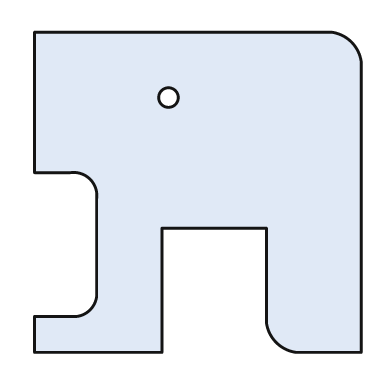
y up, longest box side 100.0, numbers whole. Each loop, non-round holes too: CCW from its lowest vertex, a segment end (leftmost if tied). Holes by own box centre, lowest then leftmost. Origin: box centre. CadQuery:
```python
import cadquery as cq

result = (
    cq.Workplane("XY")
    .moveTo(-50.0, -49.0)
    .lineTo(-11.0, -49.0)
    .lineTo(-11.0, -11.0)
    .lineTo(21.0, -11.0)
    .lineTo(21.0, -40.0)
    .threePointArc((24.0, -46.0), (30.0, -49.0))
    .lineTo(50.0, -49.0)
    .lineTo(50.0, 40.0)
    .threePointArc((47.0, 46.0), (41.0, 49.0))
    .lineTo(-50.0, 49.0)
    .lineTo(-50.0, 6.0)
    .lineTo(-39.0, 6.0)
    .threePointArc((-33.0, 4.0), (-31.0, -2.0))
    .lineTo(-31.0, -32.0)
    .threePointArc((-33.0, -36.0), (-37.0, -38.0))
    .lineTo(-50.0, -38.0)
    .close()
    .moveTo(-9.0, 29.0)
    .circle(3.0)
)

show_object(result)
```